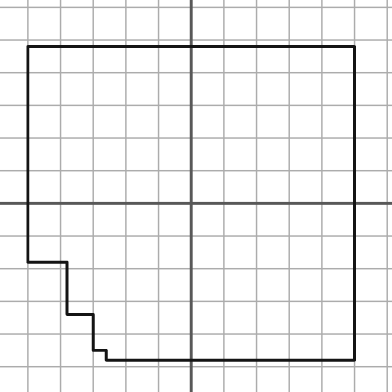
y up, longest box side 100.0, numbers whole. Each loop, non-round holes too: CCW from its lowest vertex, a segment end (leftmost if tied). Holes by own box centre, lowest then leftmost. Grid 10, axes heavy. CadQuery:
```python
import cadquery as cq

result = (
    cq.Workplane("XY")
    .moveTo(-26.0, -48.0)
    .lineTo(50.0, -48.0)
    .lineTo(50.0, 48.0)
    .lineTo(-50.0, 48.0)
    .lineTo(-50.0, -18.0)
    .lineTo(-38.0, -18.0)
    .lineTo(-38.0, -34.0)
    .lineTo(-30.0, -34.0)
    .lineTo(-30.0, -45.0)
    .lineTo(-26.0, -45.0)
    .close()
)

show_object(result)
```